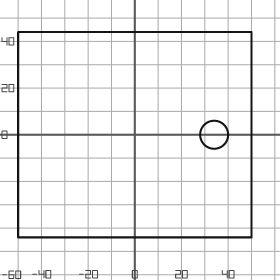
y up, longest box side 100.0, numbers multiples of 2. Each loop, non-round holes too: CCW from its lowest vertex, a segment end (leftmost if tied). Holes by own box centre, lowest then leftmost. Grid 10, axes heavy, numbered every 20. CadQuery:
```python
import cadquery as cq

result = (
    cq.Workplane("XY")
    .moveTo(-50.0, -44.0)
    .lineTo(50.0, -44.0)
    .lineTo(50.0, 44.0)
    .lineTo(-50.0, 44.0)
    .close()
    .moveTo(34.0, 0.0)
    .circle(6.0)
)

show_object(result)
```